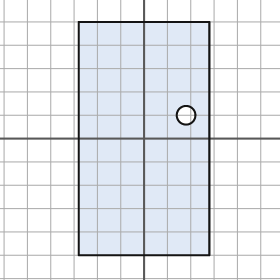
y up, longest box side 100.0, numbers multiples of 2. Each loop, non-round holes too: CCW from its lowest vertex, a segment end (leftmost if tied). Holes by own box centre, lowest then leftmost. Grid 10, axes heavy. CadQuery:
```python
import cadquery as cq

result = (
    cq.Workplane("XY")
    .moveTo(-28.0, -50.0)
    .lineTo(28.0, -50.0)
    .lineTo(28.0, 50.0)
    .lineTo(-28.0, 50.0)
    .close()
    .moveTo(18.0, 10.0)
    .circle(4.0)
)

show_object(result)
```